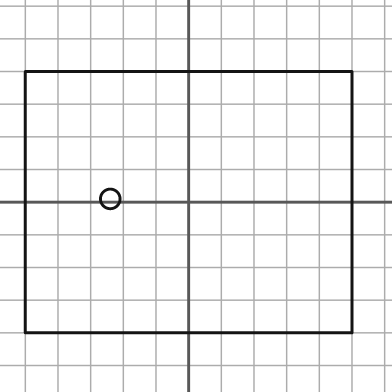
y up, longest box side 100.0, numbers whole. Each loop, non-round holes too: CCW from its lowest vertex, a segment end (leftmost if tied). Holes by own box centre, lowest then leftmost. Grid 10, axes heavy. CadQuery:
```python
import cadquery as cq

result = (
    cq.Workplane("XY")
    .moveTo(-50.0, -40.0)
    .lineTo(50.0, -40.0)
    .lineTo(50.0, 40.0)
    .lineTo(-50.0, 40.0)
    .close()
    .moveTo(-24.0, 1.0)
    .circle(3.0)
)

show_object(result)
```